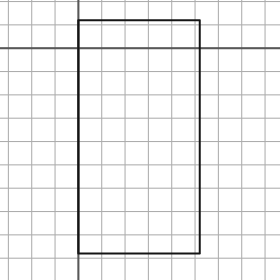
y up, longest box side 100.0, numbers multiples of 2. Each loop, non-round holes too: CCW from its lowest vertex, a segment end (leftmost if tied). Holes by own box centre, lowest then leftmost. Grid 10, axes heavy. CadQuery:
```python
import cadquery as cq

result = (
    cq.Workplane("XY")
    .moveTo(0.0, -88.0)
    .lineTo(52.0, -88.0)
    .lineTo(52.0, 12.0)
    .lineTo(0.0, 12.0)
    .close()
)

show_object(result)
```